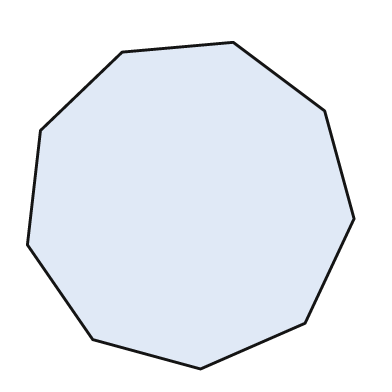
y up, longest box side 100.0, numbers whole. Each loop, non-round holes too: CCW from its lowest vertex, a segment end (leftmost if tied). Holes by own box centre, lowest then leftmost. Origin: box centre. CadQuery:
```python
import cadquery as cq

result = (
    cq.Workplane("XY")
    .moveTo(3.0, -50.0)
    .lineTo(35.0, -36.0)
    .lineTo(50.0, -4.0)
    .lineTo(41.0, 29.0)
    .lineTo(13.0, 50.0)
    .lineTo(-21.0, 47.0)
    .lineTo(-46.0, 23.0)
    .lineTo(-50.0, -12.0)
    .lineTo(-30.0, -41.0)
    .close()
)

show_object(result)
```